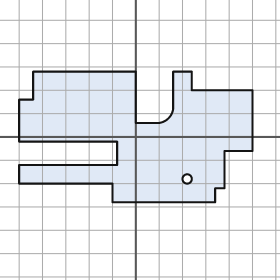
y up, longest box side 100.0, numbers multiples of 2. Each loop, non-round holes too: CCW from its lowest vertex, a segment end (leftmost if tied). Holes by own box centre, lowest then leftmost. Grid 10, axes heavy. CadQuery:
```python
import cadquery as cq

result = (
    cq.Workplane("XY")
    .moveTo(-10.0, -28.0)
    .lineTo(34.0, -28.0)
    .lineTo(34.0, -22.0)
    .lineTo(38.0, -22.0)
    .lineTo(38.0, -6.0)
    .lineTo(50.0, -6.0)
    .lineTo(50.0, 20.0)
    .lineTo(24.0, 20.0)
    .lineTo(24.0, 28.0)
    .lineTo(16.0, 28.0)
    .lineTo(16.0, 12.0)
    .threePointArc((14.0, 8.0), (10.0, 6.0))
    .lineTo(0.0, 6.0)
    .lineTo(0.0, 28.0)
    .lineTo(-44.0, 28.0)
    .lineTo(-44.0, 16.0)
    .lineTo(-50.0, 16.0)
    .lineTo(-50.0, -2.0)
    .lineTo(-8.0, -2.0)
    .lineTo(-8.0, -12.0)
    .lineTo(-50.0, -12.0)
    .lineTo(-50.0, -20.0)
    .lineTo(-10.0, -20.0)
    .close()
    .moveTo(22.0, -18.0)
    .circle(2.0)
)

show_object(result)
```